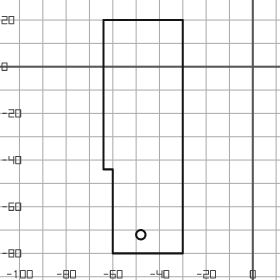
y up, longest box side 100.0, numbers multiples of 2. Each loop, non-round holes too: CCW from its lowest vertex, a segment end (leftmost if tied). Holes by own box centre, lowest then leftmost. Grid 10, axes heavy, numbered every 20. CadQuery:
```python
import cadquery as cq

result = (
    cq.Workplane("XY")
    .moveTo(-60.0, -80.0)
    .lineTo(-30.0, -80.0)
    .lineTo(-30.0, 20.0)
    .lineTo(-64.0, 20.0)
    .lineTo(-64.0, -44.0)
    .lineTo(-60.0, -44.0)
    .close()
    .moveTo(-48.0, -72.0)
    .circle(2.0)
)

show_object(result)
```